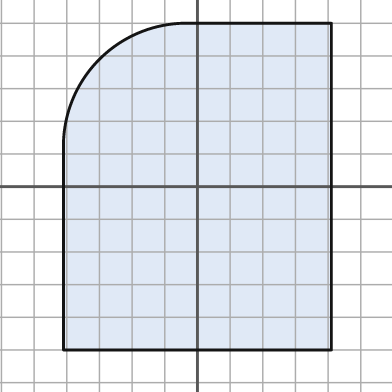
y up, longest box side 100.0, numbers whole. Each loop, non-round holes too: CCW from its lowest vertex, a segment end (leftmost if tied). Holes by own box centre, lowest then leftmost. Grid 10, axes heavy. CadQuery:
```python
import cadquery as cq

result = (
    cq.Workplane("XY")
    .moveTo(-41.0, -50.0)
    .lineTo(41.0, -50.0)
    .lineTo(41.0, 50.0)
    .lineTo(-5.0, 50.0)
    .threePointArc((-30.0, 39.0), (-41.0, 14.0))
    .close()
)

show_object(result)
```